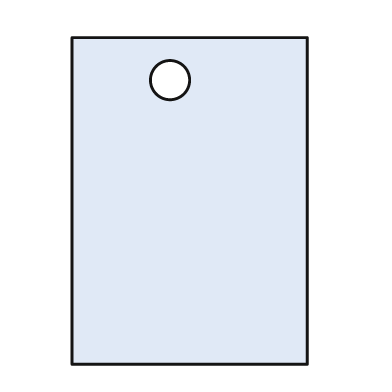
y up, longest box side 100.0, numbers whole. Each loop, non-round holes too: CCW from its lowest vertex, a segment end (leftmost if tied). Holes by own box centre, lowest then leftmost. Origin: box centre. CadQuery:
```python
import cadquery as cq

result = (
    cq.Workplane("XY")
    .moveTo(-36.0, -50.0)
    .lineTo(36.0, -50.0)
    .lineTo(36.0, 50.0)
    .lineTo(-36.0, 50.0)
    .close()
    .moveTo(-6.0, 37.0)
    .circle(6.0)
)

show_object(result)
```